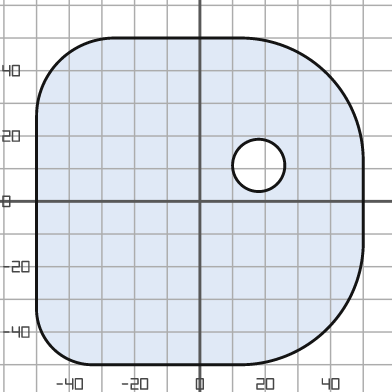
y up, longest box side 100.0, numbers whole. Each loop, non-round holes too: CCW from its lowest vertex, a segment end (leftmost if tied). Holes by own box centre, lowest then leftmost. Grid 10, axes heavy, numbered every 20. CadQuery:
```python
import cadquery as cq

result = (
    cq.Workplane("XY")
    .moveTo(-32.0, -50.0)
    .lineTo(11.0, -50.0)
    .threePointArc((39.0, -39.0), (50.0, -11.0))
    .lineTo(50.0, 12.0)
    .threePointArc((39.0, 39.0), (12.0, 50.0))
    .lineTo(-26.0, 50.0)
    .threePointArc((-43.0, 43.0), (-50.0, 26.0))
    .lineTo(-50.0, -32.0)
    .threePointArc((-45.0, -45.0), (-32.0, -50.0))
    .close()
    .moveTo(18.0, 11.0)
    .circle(8.0)
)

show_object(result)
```